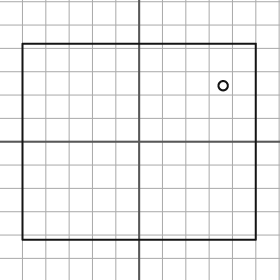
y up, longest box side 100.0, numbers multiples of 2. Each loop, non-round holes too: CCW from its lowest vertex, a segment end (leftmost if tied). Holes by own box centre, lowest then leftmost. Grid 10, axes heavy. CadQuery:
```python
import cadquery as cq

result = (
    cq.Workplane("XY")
    .moveTo(-50.0, -42.0)
    .lineTo(50.0, -42.0)
    .lineTo(50.0, 42.0)
    .lineTo(-50.0, 42.0)
    .close()
    .moveTo(36.0, 24.0)
    .circle(2.0)
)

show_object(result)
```